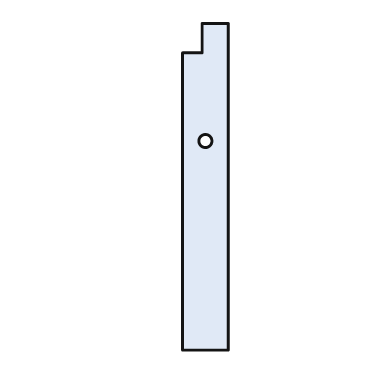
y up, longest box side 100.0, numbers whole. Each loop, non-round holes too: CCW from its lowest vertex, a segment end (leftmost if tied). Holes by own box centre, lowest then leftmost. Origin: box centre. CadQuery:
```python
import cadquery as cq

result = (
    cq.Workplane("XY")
    .moveTo(-7.0, -50.0)
    .lineTo(7.0, -50.0)
    .lineTo(7.0, 50.0)
    .lineTo(-1.0, 50.0)
    .lineTo(-1.0, 41.0)
    .lineTo(-7.0, 41.0)
    .close()
    .moveTo(0.0, 14.0)
    .circle(2.0)
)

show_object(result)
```